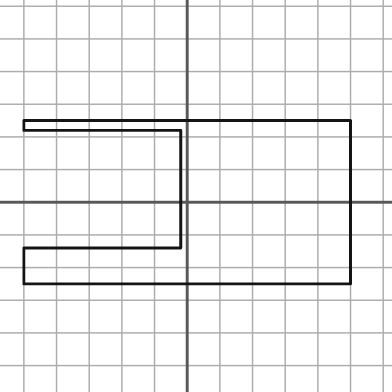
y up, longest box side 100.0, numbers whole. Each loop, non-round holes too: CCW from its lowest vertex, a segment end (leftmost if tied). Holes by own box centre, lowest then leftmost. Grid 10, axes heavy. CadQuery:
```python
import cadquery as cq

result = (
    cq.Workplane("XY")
    .moveTo(-50.0, -25.0)
    .lineTo(50.0, -25.0)
    .lineTo(50.0, 25.0)
    .lineTo(-50.0, 25.0)
    .lineTo(-50.0, 22.0)
    .lineTo(-2.0, 22.0)
    .lineTo(-2.0, -14.0)
    .lineTo(-50.0, -14.0)
    .close()
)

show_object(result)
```